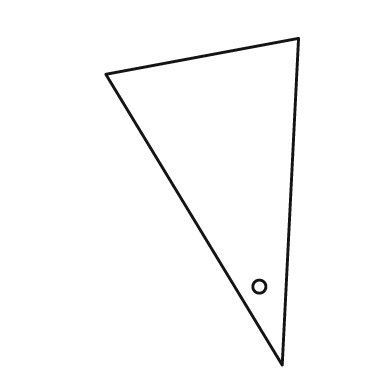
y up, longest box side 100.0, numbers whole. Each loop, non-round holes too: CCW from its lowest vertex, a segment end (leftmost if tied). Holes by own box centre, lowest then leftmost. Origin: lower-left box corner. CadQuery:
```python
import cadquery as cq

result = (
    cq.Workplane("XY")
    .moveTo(54.0, 0.0)
    .lineTo(59.0, 100.0)
    .lineTo(0.0, 89.0)
    .close()
    .moveTo(47.0, 24.0)
    .circle(2.0)
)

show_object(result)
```